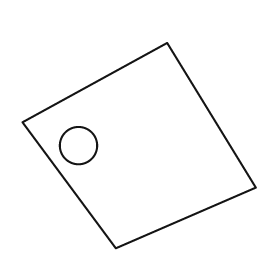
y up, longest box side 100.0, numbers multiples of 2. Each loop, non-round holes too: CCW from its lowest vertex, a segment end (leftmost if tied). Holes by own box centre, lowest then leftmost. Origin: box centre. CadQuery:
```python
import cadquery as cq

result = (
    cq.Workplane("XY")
    .moveTo(-10.0, -44.0)
    .lineTo(50.0, -18.0)
    .lineTo(12.0, 44.0)
    .lineTo(-50.0, 10.0)
    .close()
    .moveTo(-26.0, 0.0)
    .circle(8.0)
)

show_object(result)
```